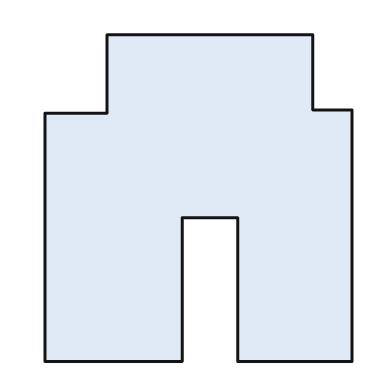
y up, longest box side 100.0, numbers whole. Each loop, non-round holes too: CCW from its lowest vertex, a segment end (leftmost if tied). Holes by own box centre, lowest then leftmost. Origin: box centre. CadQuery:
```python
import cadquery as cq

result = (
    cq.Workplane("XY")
    .moveTo(-47.0, -50.0)
    .lineTo(-5.0, -50.0)
    .lineTo(-5.0, -6.0)
    .lineTo(12.0, -6.0)
    .lineTo(12.0, -50.0)
    .lineTo(47.0, -50.0)
    .lineTo(47.0, 27.0)
    .lineTo(35.0, 27.0)
    .lineTo(35.0, 50.0)
    .lineTo(-28.0, 50.0)
    .lineTo(-28.0, 26.0)
    .lineTo(-47.0, 26.0)
    .close()
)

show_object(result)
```